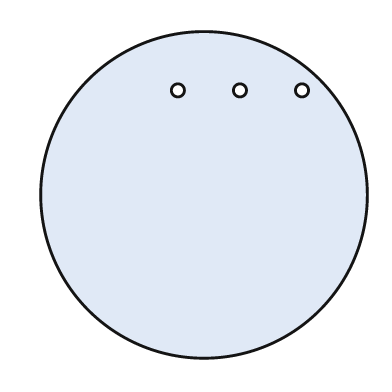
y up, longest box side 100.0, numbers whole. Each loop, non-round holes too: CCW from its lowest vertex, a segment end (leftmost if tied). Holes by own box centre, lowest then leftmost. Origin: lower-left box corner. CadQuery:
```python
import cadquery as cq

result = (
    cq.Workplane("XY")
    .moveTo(50.0, 50.0)
    .circle(50.0)
    .moveTo(42.0, 82.0)
    .circle(2.0)
    .moveTo(61.0, 82.0)
    .circle(2.0)
    .moveTo(80.0, 82.0)
    .circle(2.0)
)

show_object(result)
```